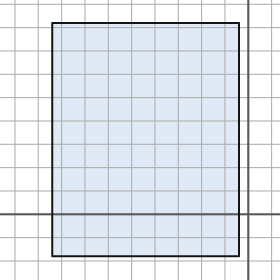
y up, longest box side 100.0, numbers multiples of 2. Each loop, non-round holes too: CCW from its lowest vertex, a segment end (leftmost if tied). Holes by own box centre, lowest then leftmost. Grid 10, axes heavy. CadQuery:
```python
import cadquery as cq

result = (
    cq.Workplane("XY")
    .moveTo(-84.0, -18.0)
    .lineTo(-4.0, -18.0)
    .lineTo(-4.0, 82.0)
    .lineTo(-84.0, 82.0)
    .close()
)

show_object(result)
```